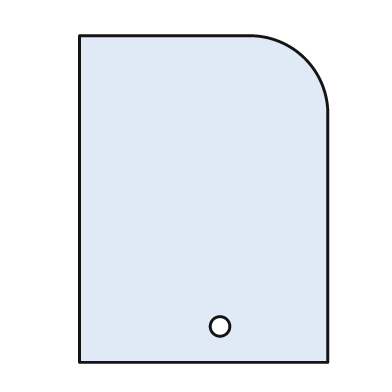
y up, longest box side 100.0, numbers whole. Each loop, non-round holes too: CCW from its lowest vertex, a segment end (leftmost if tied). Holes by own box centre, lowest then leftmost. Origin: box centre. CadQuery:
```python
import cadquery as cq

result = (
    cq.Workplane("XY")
    .moveTo(-38.0, -50.0)
    .lineTo(38.0, -50.0)
    .lineTo(38.0, 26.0)
    .threePointArc((31.0, 43.0), (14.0, 50.0))
    .lineTo(-38.0, 50.0)
    .close()
    .moveTo(5.0, -39.0)
    .circle(3.0)
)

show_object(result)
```